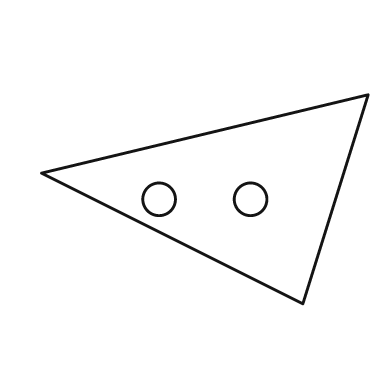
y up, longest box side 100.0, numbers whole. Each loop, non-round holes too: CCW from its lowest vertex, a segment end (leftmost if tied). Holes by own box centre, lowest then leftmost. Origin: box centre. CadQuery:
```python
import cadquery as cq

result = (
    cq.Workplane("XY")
    .moveTo(30.0, -32.0)
    .lineTo(50.0, 32.0)
    .lineTo(-50.0, 8.0)
    .close()
    .moveTo(-14.0, 0.0)
    .circle(5.0)
    .moveTo(14.0, 0.0)
    .circle(5.0)
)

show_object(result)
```